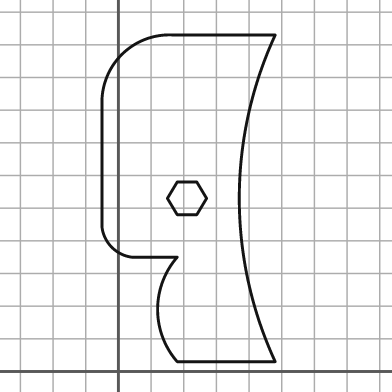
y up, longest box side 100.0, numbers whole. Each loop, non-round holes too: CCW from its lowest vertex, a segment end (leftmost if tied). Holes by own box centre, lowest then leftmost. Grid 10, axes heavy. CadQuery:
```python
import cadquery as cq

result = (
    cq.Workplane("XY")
    .moveTo(18.0, 3.0)
    .lineTo(48.0, 3.0)
    .threePointArc((37.0, 53.0), (48.0, 103.0))
    .lineTo(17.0, 103.0)
    .threePointArc((1.0, 97.0), (-5.0, 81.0))
    .lineTo(-5.0, 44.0)
    .threePointArc((-2.0, 38.0), (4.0, 35.0))
    .lineTo(18.0, 35.0)
    .threePointArc((12.0, 19.0), (18.0, 3.0))
    .close()
    .moveTo(18.0, 48.0)
    .lineTo(24.0, 48.0)
    .lineTo(27.0, 53.0)
    .lineTo(24.0, 58.0)
    .lineTo(18.0, 58.0)
    .lineTo(15.0, 53.0)
    .close()
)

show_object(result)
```